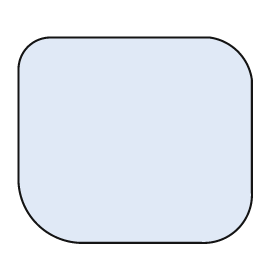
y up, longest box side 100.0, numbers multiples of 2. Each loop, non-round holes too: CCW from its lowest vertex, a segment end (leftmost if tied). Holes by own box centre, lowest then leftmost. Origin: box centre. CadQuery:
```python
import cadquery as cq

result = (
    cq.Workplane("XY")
    .moveTo(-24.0, -44.0)
    .lineTo(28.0, -44.0)
    .threePointArc((44.0, -38.0), (50.0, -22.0))
    .lineTo(50.0, 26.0)
    .threePointArc((44.0, 38.0), (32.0, 44.0))
    .lineTo(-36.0, 44.0)
    .threePointArc((-46.0, 40.0), (-50.0, 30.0))
    .lineTo(-50.0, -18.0)
    .threePointArc((-42.0, -36.0), (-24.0, -44.0))
    .close()
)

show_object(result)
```